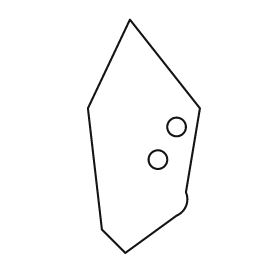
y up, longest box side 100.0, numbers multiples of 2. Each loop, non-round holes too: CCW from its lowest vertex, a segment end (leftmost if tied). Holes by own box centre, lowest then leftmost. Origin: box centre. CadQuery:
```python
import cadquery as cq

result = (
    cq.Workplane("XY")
    .moveTo(-8.0, -50.0)
    .lineTo(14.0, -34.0)
    .threePointArc((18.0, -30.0), (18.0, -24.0))
    .lineTo(24.0, 12.0)
    .lineTo(-6.0, 50.0)
    .lineTo(-24.0, 12.0)
    .lineTo(-18.0, -40.0)
    .close()
    .moveTo(6.0, -10.0)
    .circle(4.0)
    .moveTo(14.0, 4.0)
    .circle(4.0)
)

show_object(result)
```